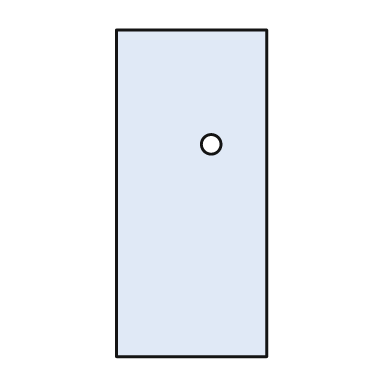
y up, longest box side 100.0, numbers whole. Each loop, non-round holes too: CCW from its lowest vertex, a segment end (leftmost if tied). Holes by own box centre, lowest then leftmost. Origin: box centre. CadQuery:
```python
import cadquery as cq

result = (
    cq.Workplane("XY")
    .moveTo(-23.0, -50.0)
    .lineTo(23.0, -50.0)
    .lineTo(23.0, 50.0)
    .lineTo(-23.0, 50.0)
    .close()
    .moveTo(6.0, 15.0)
    .circle(3.0)
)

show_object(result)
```